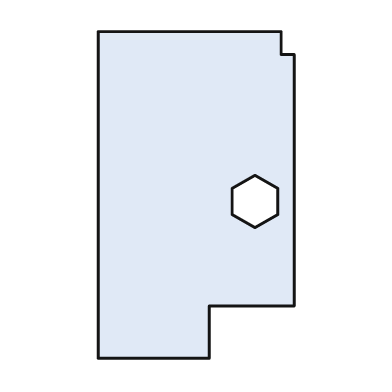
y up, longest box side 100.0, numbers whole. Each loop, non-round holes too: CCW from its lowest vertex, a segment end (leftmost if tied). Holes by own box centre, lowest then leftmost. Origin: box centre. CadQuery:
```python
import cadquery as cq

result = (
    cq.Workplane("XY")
    .moveTo(-30.0, -50.0)
    .lineTo(4.0, -50.0)
    .lineTo(4.0, -34.0)
    .lineTo(30.0, -34.0)
    .lineTo(30.0, 43.0)
    .lineTo(26.0, 43.0)
    .lineTo(26.0, 50.0)
    .lineTo(-30.0, 50.0)
    .close()
    .moveTo(18.0, -10.0)
    .lineTo(25.0, -6.0)
    .lineTo(25.0, 2.0)
    .lineTo(18.0, 6.0)
    .lineTo(11.0, 2.0)
    .lineTo(11.0, -6.0)
    .close()
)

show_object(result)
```